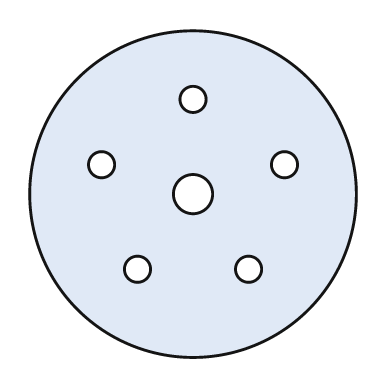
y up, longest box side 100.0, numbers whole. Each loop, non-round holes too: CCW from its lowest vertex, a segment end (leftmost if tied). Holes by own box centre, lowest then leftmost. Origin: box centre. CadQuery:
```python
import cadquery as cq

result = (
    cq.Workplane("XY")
    .moveTo(0.0, 0.0)
    .circle(50.0)
    .moveTo(-17.0, -23.0)
    .circle(4.0)
    .moveTo(17.0, -23.0)
    .circle(4.0)
    .moveTo(0.0, 0.0)
    .circle(6.0)
    .moveTo(-28.0, 9.0)
    .circle(4.0)
    .moveTo(28.0, 9.0)
    .circle(4.0)
    .moveTo(0.0, 29.0)
    .circle(4.0)
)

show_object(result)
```